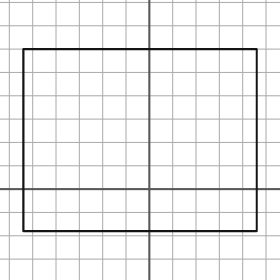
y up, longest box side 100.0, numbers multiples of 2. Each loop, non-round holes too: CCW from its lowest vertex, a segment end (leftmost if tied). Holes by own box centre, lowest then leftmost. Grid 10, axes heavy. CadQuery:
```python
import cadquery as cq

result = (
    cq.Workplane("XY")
    .moveTo(-54.0, -18.0)
    .lineTo(46.0, -18.0)
    .lineTo(46.0, 60.0)
    .lineTo(-54.0, 60.0)
    .close()
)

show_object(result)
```